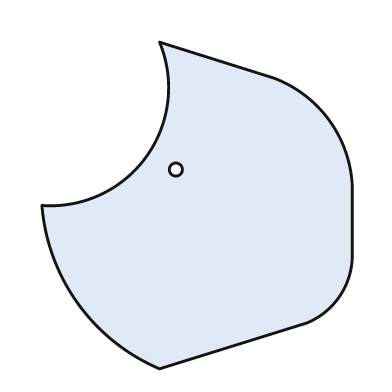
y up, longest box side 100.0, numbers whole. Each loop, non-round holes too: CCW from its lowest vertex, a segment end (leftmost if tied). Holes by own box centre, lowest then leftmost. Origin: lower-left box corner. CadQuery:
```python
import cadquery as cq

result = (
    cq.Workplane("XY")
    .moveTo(36.0, 0.0)
    .lineTo(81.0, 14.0)
    .threePointArc((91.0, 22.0), (95.0, 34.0))
    .lineTo(95.0, 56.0)
    .threePointArc((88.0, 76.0), (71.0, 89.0))
    .lineTo(36.0, 100.0)
    .threePointArc((32.0, 65.0), (0.0, 50.0))
    .threePointArc((11.0, 20.0), (36.0, 0.0))
    .close()
    .moveTo(41.0, 61.0)
    .circle(2.0)
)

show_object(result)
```